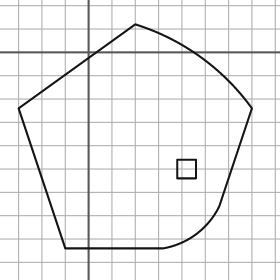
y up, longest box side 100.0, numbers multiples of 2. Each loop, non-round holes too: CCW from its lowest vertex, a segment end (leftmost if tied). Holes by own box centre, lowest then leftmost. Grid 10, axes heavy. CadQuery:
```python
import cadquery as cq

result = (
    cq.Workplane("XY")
    .moveTo(-10.0, -84.0)
    .lineTo(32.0, -84.0)
    .threePointArc((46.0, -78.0), (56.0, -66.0))
    .lineTo(70.0, -24.0)
    .threePointArc((48.0, -2.0), (20.0, 12.0))
    .lineTo(-30.0, -24.0)
    .close()
    .moveTo(38.0, -54.0)
    .lineTo(46.0, -54.0)
    .lineTo(46.0, -46.0)
    .lineTo(38.0, -46.0)
    .close()
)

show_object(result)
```